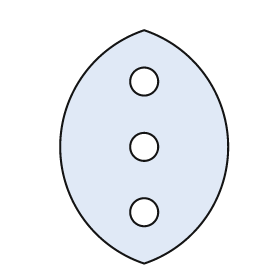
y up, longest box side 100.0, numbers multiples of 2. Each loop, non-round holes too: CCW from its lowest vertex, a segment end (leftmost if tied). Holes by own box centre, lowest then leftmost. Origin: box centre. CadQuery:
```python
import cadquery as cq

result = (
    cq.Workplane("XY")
    .moveTo(0.0, -50.0)
    .threePointArc((36.0, 0.0), (0.0, 50.0))
    .threePointArc((-36.0, 0.0), (0.0, -50.0))
    .close()
    .moveTo(0.0, -28.0)
    .circle(6.0)
    .moveTo(0.0, 0.0)
    .circle(6.0)
    .moveTo(0.0, 28.0)
    .circle(6.0)
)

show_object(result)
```